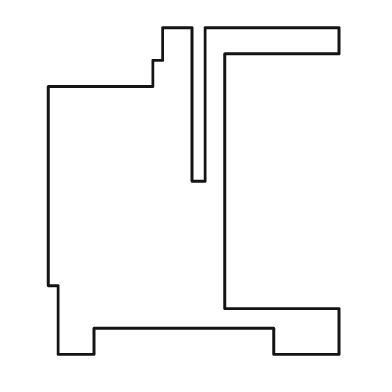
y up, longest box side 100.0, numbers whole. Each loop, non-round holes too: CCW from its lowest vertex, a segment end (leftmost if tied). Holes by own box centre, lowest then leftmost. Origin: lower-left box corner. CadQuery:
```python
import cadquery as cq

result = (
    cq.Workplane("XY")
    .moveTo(3.0, 0.0)
    .lineTo(14.0, 0.0)
    .lineTo(14.0, 8.0)
    .lineTo(69.0, 8.0)
    .lineTo(69.0, 0.0)
    .lineTo(89.0, 0.0)
    .lineTo(89.0, 14.0)
    .lineTo(54.0, 14.0)
    .lineTo(54.0, 92.0)
    .lineTo(89.0, 92.0)
    .lineTo(89.0, 100.0)
    .lineTo(48.0, 100.0)
    .lineTo(48.0, 53.0)
    .lineTo(44.0, 53.0)
    .lineTo(44.0, 100.0)
    .lineTo(35.0, 100.0)
    .lineTo(35.0, 90.0)
    .lineTo(32.0, 90.0)
    .lineTo(32.0, 82.0)
    .lineTo(0.0, 82.0)
    .lineTo(0.0, 21.0)
    .lineTo(3.0, 21.0)
    .close()
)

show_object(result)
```